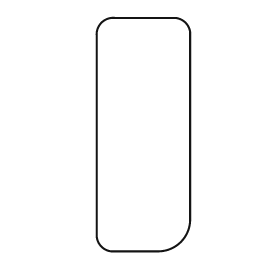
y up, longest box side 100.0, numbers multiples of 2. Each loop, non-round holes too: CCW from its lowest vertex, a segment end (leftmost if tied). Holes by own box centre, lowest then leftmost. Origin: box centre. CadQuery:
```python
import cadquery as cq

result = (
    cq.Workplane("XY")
    .moveTo(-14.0, -50.0)
    .lineTo(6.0, -50.0)
    .threePointArc((16.0, -46.0), (20.0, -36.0))
    .lineTo(20.0, 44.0)
    .threePointArc((18.0, 48.0), (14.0, 50.0))
    .lineTo(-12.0, 50.0)
    .threePointArc((-18.0, 48.0), (-20.0, 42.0))
    .lineTo(-20.0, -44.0)
    .threePointArc((-18.0, -48.0), (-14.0, -50.0))
    .close()
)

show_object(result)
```